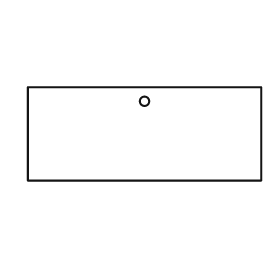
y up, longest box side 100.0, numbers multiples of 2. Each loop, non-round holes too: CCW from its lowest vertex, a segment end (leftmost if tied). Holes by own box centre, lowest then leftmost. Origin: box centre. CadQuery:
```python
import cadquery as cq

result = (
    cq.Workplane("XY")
    .moveTo(-50.0, -20.0)
    .lineTo(50.0, -20.0)
    .lineTo(50.0, 20.0)
    .lineTo(-50.0, 20.0)
    .close()
    .moveTo(0.0, 14.0)
    .circle(2.0)
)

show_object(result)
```